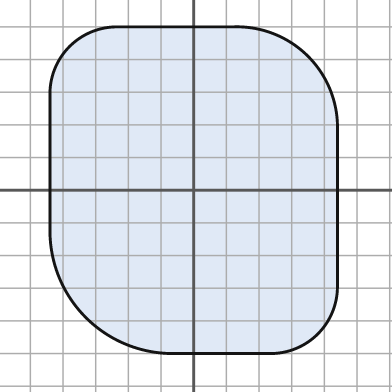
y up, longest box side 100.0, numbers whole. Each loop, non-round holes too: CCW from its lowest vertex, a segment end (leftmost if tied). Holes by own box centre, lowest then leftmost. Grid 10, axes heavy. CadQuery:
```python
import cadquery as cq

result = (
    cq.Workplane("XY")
    .moveTo(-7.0, -50.0)
    .lineTo(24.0, -50.0)
    .threePointArc((38.0, -44.0), (44.0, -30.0))
    .lineTo(44.0, 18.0)
    .threePointArc((35.0, 41.0), (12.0, 50.0))
    .lineTo(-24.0, 50.0)
    .threePointArc((-38.0, 44.0), (-44.0, 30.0))
    .lineTo(-44.0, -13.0)
    .threePointArc((-33.0, -39.0), (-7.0, -50.0))
    .close()
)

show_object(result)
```